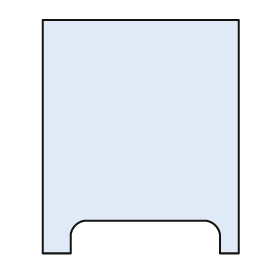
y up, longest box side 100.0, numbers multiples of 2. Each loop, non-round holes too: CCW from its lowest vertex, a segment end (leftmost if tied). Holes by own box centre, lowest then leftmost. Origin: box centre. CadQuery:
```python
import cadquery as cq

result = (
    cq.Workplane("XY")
    .moveTo(-42.0, -50.0)
    .lineTo(-30.0, -50.0)
    .lineTo(-30.0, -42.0)
    .threePointArc((-28.0, -38.0), (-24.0, -36.0))
    .lineTo(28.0, -36.0)
    .threePointArc((32.0, -38.0), (34.0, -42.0))
    .lineTo(34.0, -50.0)
    .lineTo(42.0, -50.0)
    .lineTo(42.0, 50.0)
    .lineTo(-42.0, 50.0)
    .close()
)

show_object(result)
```